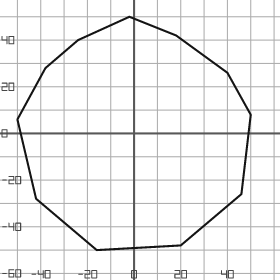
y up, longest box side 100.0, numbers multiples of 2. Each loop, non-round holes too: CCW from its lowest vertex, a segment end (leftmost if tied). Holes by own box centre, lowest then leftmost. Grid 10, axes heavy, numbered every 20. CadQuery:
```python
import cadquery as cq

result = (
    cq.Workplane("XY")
    .moveTo(-16.0, -50.0)
    .lineTo(20.0, -48.0)
    .lineTo(46.0, -26.0)
    .lineTo(50.0, 8.0)
    .lineTo(40.0, 26.0)
    .lineTo(18.0, 42.0)
    .lineTo(-2.0, 50.0)
    .lineTo(-24.0, 40.0)
    .lineTo(-38.0, 28.0)
    .lineTo(-50.0, 6.0)
    .lineTo(-42.0, -28.0)
    .close()
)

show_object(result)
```